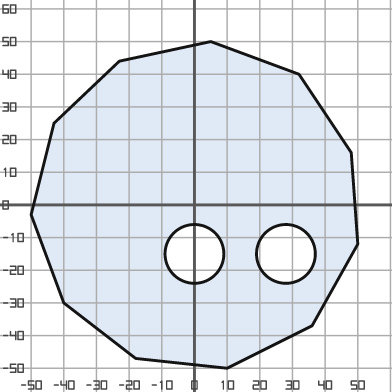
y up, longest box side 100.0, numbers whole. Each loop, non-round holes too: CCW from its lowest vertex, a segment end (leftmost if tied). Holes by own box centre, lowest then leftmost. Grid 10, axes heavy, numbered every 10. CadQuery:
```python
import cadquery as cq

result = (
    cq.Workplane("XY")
    .moveTo(10.0, -50.0)
    .lineTo(36.0, -37.0)
    .lineTo(50.0, -12.0)
    .lineTo(48.0, 16.0)
    .lineTo(32.0, 40.0)
    .lineTo(5.0, 50.0)
    .lineTo(-23.0, 44.0)
    .lineTo(-43.0, 25.0)
    .lineTo(-50.0, -3.0)
    .lineTo(-40.0, -30.0)
    .lineTo(-18.0, -47.0)
    .close()
    .moveTo(0.0, -15.0)
    .circle(9.0)
    .moveTo(28.0, -15.0)
    .circle(9.0)
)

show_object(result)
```